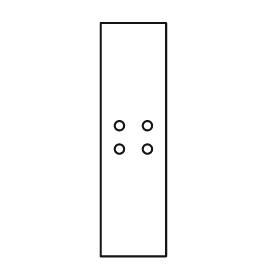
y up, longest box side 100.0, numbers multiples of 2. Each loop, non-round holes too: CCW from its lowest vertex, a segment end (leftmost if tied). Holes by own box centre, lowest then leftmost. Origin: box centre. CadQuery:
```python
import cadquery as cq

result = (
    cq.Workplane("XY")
    .moveTo(-14.0, -50.0)
    .lineTo(14.0, -50.0)
    .lineTo(14.0, 50.0)
    .lineTo(-14.0, 50.0)
    .close()
    .moveTo(-6.0, -4.0)
    .circle(2.0)
    .moveTo(6.0, -4.0)
    .circle(2.0)
    .moveTo(-6.0, 6.0)
    .circle(2.0)
    .moveTo(6.0, 6.0)
    .circle(2.0)
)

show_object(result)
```